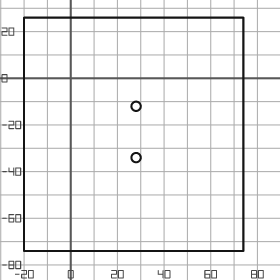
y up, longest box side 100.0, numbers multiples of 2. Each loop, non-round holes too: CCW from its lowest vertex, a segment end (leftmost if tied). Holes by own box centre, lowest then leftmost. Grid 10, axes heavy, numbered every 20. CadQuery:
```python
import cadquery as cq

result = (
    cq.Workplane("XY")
    .moveTo(-20.0, -74.0)
    .lineTo(74.0, -74.0)
    .lineTo(74.0, 26.0)
    .lineTo(-20.0, 26.0)
    .close()
    .moveTo(28.0, -34.0)
    .circle(2.0)
    .moveTo(28.0, -12.0)
    .circle(2.0)
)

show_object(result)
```